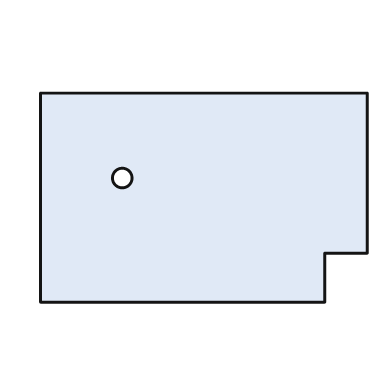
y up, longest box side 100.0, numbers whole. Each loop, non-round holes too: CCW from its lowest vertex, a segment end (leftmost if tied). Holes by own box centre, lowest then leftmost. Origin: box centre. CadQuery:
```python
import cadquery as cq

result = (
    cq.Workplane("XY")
    .moveTo(-50.0, -32.0)
    .lineTo(37.0, -32.0)
    .lineTo(37.0, -17.0)
    .lineTo(50.0, -17.0)
    .lineTo(50.0, 32.0)
    .lineTo(-50.0, 32.0)
    .close()
    .moveTo(-25.0, 6.0)
    .circle(3.0)
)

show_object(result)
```